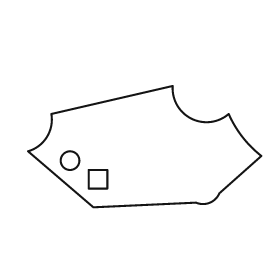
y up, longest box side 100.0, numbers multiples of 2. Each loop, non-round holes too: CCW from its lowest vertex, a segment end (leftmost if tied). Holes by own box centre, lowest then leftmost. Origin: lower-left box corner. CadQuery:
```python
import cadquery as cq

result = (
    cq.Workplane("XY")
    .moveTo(28.0, 0.0)
    .lineTo(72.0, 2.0)
    .threePointArc((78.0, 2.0), (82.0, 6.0))
    .lineTo(100.0, 22.0)
    .threePointArc((92.0, 30.0), (86.0, 40.0))
    .threePointArc((70.0, 38.0), (62.0, 52.0))
    .lineTo(10.0, 40.0)
    .threePointArc((8.0, 30.0), (0.0, 24.0))
    .close()
    .moveTo(26.0, 8.0)
    .lineTo(34.0, 8.0)
    .lineTo(34.0, 16.0)
    .lineTo(26.0, 16.0)
    .close()
    .moveTo(18.0, 20.0)
    .circle(4.0)
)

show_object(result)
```